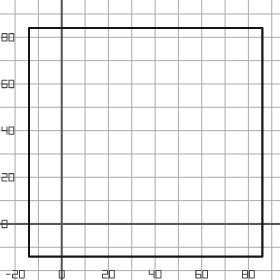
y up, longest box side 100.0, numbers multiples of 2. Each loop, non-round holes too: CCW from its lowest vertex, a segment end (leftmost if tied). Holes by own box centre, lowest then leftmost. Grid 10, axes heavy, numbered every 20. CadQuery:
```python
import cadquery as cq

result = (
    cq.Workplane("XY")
    .moveTo(-14.0, -14.0)
    .lineTo(86.0, -14.0)
    .lineTo(86.0, 84.0)
    .lineTo(-14.0, 84.0)
    .close()
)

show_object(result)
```